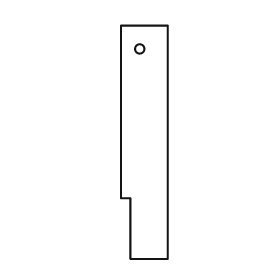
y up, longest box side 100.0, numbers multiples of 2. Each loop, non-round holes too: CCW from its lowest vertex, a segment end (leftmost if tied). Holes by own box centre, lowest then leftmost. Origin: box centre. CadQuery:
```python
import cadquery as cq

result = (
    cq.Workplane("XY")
    .moveTo(-6.0, -50.0)
    .lineTo(10.0, -50.0)
    .lineTo(10.0, 50.0)
    .lineTo(-10.0, 50.0)
    .lineTo(-10.0, -24.0)
    .lineTo(-6.0, -24.0)
    .close()
    .moveTo(-2.0, 40.0)
    .circle(2.0)
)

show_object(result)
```